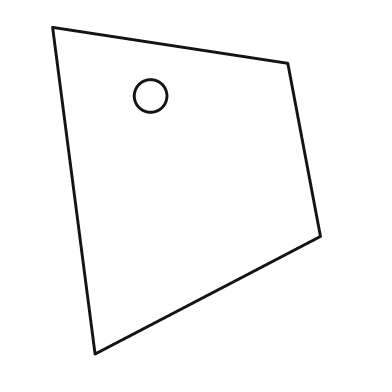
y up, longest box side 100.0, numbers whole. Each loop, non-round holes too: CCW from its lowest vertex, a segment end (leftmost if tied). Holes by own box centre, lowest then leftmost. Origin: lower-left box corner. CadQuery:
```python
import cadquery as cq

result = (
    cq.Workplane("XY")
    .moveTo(13.0, 0.0)
    .lineTo(82.0, 36.0)
    .lineTo(72.0, 89.0)
    .lineTo(0.0, 100.0)
    .close()
    .moveTo(30.0, 79.0)
    .circle(5.0)
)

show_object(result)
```